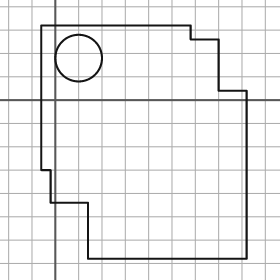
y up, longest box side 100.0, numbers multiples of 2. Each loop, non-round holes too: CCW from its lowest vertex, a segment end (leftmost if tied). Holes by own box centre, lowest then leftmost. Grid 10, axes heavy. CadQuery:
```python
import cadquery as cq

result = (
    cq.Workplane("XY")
    .moveTo(14.0, -68.0)
    .lineTo(82.0, -68.0)
    .lineTo(82.0, 4.0)
    .lineTo(70.0, 4.0)
    .lineTo(70.0, 26.0)
    .lineTo(58.0, 26.0)
    .lineTo(58.0, 32.0)
    .lineTo(-6.0, 32.0)
    .lineTo(-6.0, -30.0)
    .lineTo(-2.0, -30.0)
    .lineTo(-2.0, -44.0)
    .lineTo(14.0, -44.0)
    .close()
    .moveTo(10.0, 18.0)
    .circle(10.0)
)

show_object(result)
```